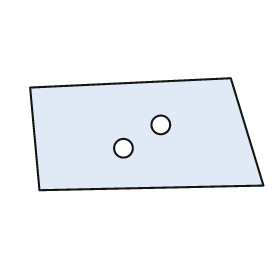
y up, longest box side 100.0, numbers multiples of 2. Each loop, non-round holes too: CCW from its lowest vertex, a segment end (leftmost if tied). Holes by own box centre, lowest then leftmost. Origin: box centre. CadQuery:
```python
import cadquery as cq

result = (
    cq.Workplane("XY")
    .moveTo(-46.0, -24.0)
    .lineTo(50.0, -22.0)
    .lineTo(36.0, 24.0)
    .lineTo(-50.0, 20.0)
    .close()
    .moveTo(-10.0, -6.0)
    .circle(4.0)
    .moveTo(6.0, 4.0)
    .circle(4.0)
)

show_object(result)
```